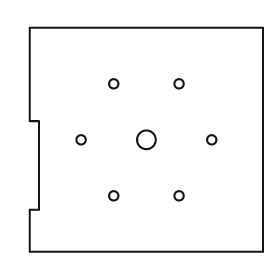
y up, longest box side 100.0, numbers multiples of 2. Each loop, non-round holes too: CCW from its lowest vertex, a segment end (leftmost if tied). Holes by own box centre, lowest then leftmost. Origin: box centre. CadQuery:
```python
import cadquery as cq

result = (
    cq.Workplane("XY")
    .moveTo(-50.0, -48.0)
    .lineTo(50.0, -48.0)
    .lineTo(50.0, 48.0)
    .lineTo(-50.0, 48.0)
    .lineTo(-50.0, 8.0)
    .lineTo(-46.0, 8.0)
    .lineTo(-46.0, -30.0)
    .lineTo(-50.0, -30.0)
    .close()
    .moveTo(-14.0, -24.0)
    .circle(2.0)
    .moveTo(14.0, -24.0)
    .circle(2.0)
    .moveTo(-28.0, 0.0)
    .circle(2.0)
    .moveTo(0.0, 0.0)
    .circle(4.0)
    .moveTo(28.0, 0.0)
    .circle(2.0)
    .moveTo(-14.0, 24.0)
    .circle(2.0)
    .moveTo(14.0, 24.0)
    .circle(2.0)
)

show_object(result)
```